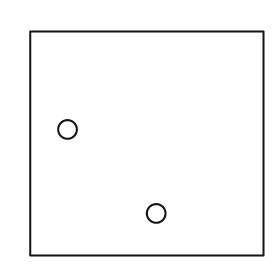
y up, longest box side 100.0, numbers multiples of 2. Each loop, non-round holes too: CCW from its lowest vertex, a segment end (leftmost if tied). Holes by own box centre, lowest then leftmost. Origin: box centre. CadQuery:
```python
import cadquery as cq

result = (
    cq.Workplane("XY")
    .moveTo(-50.0, -48.0)
    .lineTo(50.0, -48.0)
    .lineTo(50.0, 48.0)
    .lineTo(-50.0, 48.0)
    .close()
    .moveTo(4.0, -30.0)
    .circle(4.0)
    .moveTo(-34.0, 6.0)
    .circle(4.0)
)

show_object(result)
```